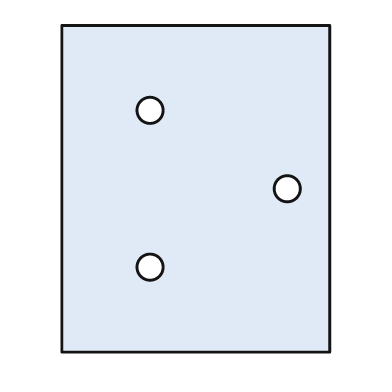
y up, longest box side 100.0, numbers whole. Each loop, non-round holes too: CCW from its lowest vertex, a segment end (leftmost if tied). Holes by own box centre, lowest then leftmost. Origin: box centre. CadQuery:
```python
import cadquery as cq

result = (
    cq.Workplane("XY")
    .moveTo(-41.0, -50.0)
    .lineTo(41.0, -50.0)
    .lineTo(41.0, 50.0)
    .lineTo(-41.0, 50.0)
    .close()
    .moveTo(-14.0, -24.0)
    .circle(4.0)
    .moveTo(28.0, 0.0)
    .circle(4.0)
    .moveTo(-14.0, 24.0)
    .circle(4.0)
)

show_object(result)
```